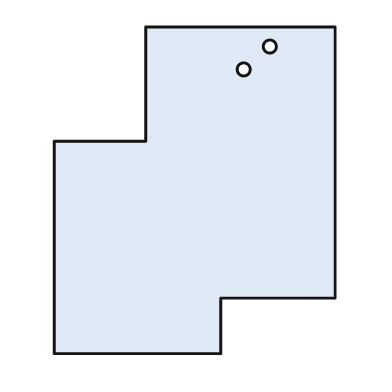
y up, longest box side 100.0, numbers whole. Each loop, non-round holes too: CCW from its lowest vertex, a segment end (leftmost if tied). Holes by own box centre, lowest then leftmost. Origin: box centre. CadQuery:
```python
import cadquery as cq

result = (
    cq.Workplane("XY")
    .moveTo(-43.0, -50.0)
    .lineTo(8.0, -50.0)
    .lineTo(8.0, -33.0)
    .lineTo(43.0, -33.0)
    .lineTo(43.0, 50.0)
    .lineTo(-15.0, 50.0)
    .lineTo(-15.0, 15.0)
    .lineTo(-43.0, 15.0)
    .close()
    .moveTo(15.0, 37.0)
    .circle(2.0)
    .moveTo(23.0, 44.0)
    .circle(2.0)
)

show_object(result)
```